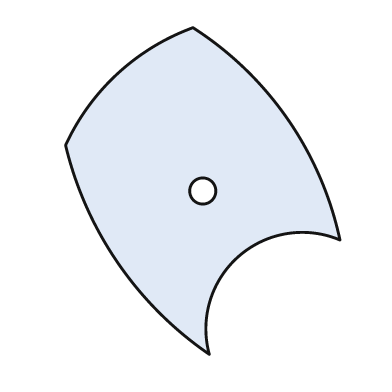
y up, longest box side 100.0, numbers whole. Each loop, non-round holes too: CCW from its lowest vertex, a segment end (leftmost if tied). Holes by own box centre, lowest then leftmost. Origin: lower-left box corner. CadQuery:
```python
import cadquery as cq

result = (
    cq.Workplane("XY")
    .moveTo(44.0, 0.0)
    .threePointArc((53.0, 30.0), (84.0, 35.0))
    .threePointArc((68.0, 72.0), (39.0, 100.0))
    .threePointArc((16.0, 86.0), (0.0, 64.0))
    .threePointArc((16.0, 28.0), (44.0, 0.0))
    .close()
    .moveTo(42.0, 50.0)
    .circle(4.0)
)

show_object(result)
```